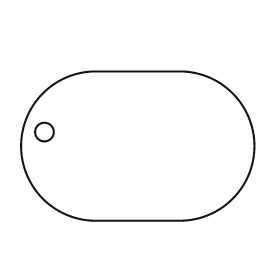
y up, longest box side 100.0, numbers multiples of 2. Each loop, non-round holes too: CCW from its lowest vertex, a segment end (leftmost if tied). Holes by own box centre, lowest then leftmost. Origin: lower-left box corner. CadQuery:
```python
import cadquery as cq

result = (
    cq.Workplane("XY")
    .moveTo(32.0, 0.0)
    .lineTo(68.0, 0.0)
    .threePointArc((100.0, 32.0), (68.0, 64.0))
    .lineTo(32.0, 64.0)
    .threePointArc((0.0, 32.0), (32.0, 0.0))
    .close()
    .moveTo(10.0, 38.0)
    .circle(4.0)
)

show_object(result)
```